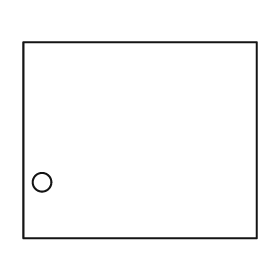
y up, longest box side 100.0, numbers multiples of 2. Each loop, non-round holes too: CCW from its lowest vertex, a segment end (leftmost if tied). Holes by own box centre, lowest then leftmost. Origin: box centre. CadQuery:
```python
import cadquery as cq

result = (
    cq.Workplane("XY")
    .moveTo(-50.0, -42.0)
    .lineTo(50.0, -42.0)
    .lineTo(50.0, 42.0)
    .lineTo(-50.0, 42.0)
    .close()
    .moveTo(-42.0, -18.0)
    .circle(4.0)
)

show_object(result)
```